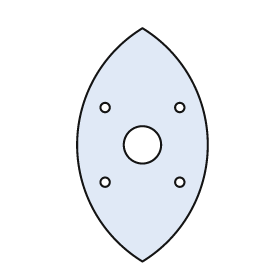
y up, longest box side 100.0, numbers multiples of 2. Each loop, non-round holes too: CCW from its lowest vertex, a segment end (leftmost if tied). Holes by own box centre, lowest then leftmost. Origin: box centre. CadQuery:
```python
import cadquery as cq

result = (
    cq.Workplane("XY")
    .moveTo(0.0, -50.0)
    .threePointArc((28.0, 0.0), (0.0, 50.0))
    .threePointArc((-28.0, 0.0), (0.0, -50.0))
    .close()
    .moveTo(-16.0, -16.0)
    .circle(2.0)
    .moveTo(16.0, -16.0)
    .circle(2.0)
    .moveTo(0.0, 0.0)
    .circle(8.0)
    .moveTo(-16.0, 16.0)
    .circle(2.0)
    .moveTo(16.0, 16.0)
    .circle(2.0)
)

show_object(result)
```